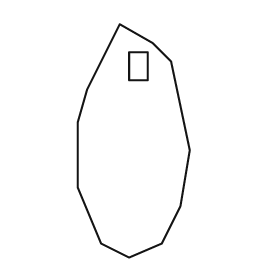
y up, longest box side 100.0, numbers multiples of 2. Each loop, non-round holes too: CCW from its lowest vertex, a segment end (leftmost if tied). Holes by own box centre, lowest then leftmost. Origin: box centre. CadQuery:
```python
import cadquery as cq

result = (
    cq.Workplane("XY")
    .moveTo(-2.0, -50.0)
    .lineTo(12.0, -44.0)
    .lineTo(20.0, -28.0)
    .lineTo(24.0, -4.0)
    .lineTo(16.0, 34.0)
    .lineTo(8.0, 42.0)
    .lineTo(-6.0, 50.0)
    .lineTo(-20.0, 22.0)
    .lineTo(-24.0, 8.0)
    .lineTo(-24.0, -20.0)
    .lineTo(-14.0, -44.0)
    .close()
    .moveTo(-2.0, 26.0)
    .lineTo(6.0, 26.0)
    .lineTo(6.0, 38.0)
    .lineTo(-2.0, 38.0)
    .close()
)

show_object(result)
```